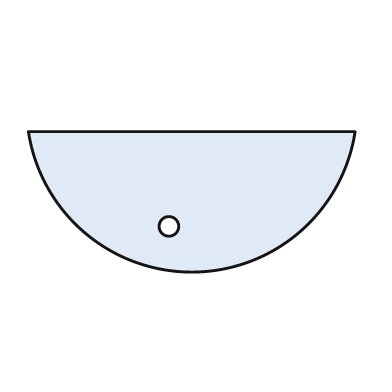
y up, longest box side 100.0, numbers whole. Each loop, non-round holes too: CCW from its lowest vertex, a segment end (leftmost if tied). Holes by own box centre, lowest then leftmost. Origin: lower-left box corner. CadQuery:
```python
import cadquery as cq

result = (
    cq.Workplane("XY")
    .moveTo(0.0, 43.0)
    .threePointArc((50.0, 0.0), (100.0, 43.0))
    .close()
    .moveTo(43.0, 14.0)
    .circle(3.0)
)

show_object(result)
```